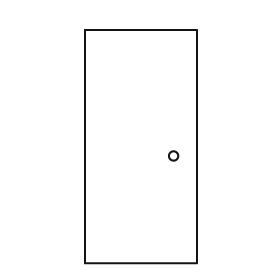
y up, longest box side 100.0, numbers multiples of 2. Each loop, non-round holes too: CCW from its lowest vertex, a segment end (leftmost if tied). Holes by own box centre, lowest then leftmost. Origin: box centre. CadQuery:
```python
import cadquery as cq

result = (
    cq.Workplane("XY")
    .moveTo(-24.0, -50.0)
    .lineTo(24.0, -50.0)
    .lineTo(24.0, 50.0)
    .lineTo(-24.0, 50.0)
    .close()
    .moveTo(14.0, -4.0)
    .circle(2.0)
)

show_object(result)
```